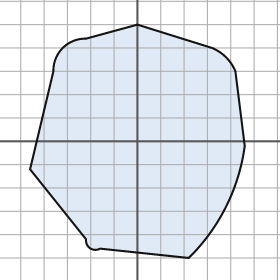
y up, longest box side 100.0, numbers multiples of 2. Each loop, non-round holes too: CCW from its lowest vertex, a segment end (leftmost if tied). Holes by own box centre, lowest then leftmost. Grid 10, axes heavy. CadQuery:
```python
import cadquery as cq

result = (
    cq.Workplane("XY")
    .moveTo(22.0, -50.0)
    .threePointArc((38.0, -28.0), (46.0, -2.0))
    .lineTo(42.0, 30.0)
    .threePointArc((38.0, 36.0), (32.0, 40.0))
    .lineTo(0.0, 50.0)
    .lineTo(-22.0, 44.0)
    .threePointArc((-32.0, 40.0), (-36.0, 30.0))
    .lineTo(-46.0, -12.0)
    .lineTo(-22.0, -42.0)
    .threePointArc((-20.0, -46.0), (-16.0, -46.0))
    .close()
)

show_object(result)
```